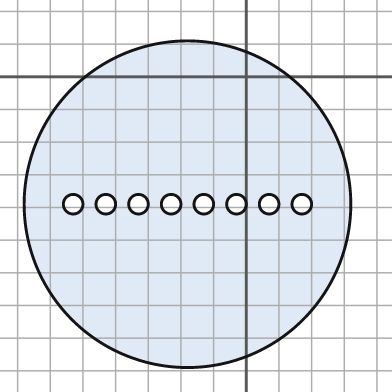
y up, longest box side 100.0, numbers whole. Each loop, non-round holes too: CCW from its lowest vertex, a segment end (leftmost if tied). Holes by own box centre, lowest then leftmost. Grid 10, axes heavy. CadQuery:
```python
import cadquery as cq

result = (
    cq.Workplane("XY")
    .moveTo(-18.0, -39.0)
    .circle(50.0)
    .moveTo(-53.0, -39.0)
    .circle(3.0)
    .moveTo(-43.0, -39.0)
    .circle(3.0)
    .moveTo(-33.0, -39.0)
    .circle(3.0)
    .moveTo(-23.0, -39.0)
    .circle(3.0)
    .moveTo(-13.0, -39.0)
    .circle(3.0)
    .moveTo(-3.0, -39.0)
    .circle(3.0)
    .moveTo(7.0, -39.0)
    .circle(3.0)
    .moveTo(17.0, -39.0)
    .circle(3.0)
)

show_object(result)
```